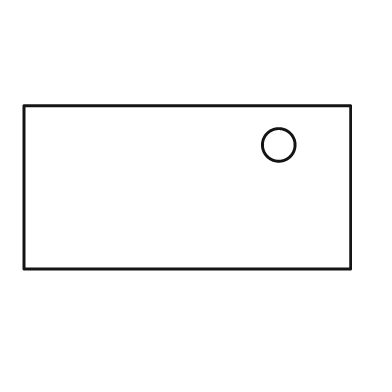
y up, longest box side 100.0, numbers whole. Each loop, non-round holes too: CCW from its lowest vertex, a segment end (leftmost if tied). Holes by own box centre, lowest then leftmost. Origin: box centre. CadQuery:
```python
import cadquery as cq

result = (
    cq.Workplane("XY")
    .moveTo(-50.0, -25.0)
    .lineTo(50.0, -25.0)
    .lineTo(50.0, 25.0)
    .lineTo(-50.0, 25.0)
    .close()
    .moveTo(28.0, 13.0)
    .circle(5.0)
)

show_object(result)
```